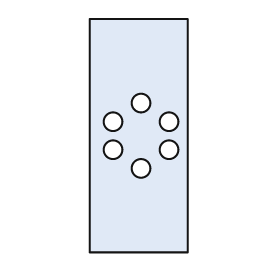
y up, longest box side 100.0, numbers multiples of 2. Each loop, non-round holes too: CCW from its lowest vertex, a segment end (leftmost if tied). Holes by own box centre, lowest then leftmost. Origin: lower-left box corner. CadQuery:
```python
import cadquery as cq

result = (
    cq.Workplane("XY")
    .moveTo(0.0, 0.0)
    .lineTo(42.0, 0.0)
    .lineTo(42.0, 100.0)
    .lineTo(0.0, 100.0)
    .close()
    .moveTo(22.0, 36.0)
    .circle(4.0)
    .moveTo(10.0, 44.0)
    .circle(4.0)
    .moveTo(34.0, 44.0)
    .circle(4.0)
    .moveTo(10.0, 56.0)
    .circle(4.0)
    .moveTo(34.0, 56.0)
    .circle(4.0)
    .moveTo(22.0, 64.0)
    .circle(4.0)
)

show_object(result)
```